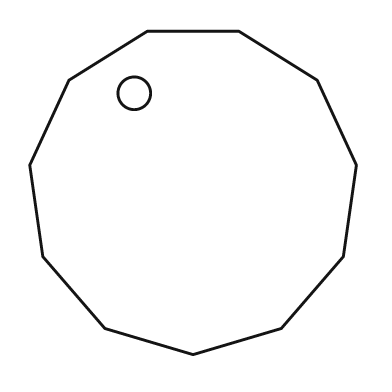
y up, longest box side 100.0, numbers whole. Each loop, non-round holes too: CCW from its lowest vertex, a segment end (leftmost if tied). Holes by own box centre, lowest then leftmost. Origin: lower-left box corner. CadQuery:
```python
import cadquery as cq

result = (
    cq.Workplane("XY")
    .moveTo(50.0, 0.0)
    .lineTo(77.0, 8.0)
    .lineTo(96.0, 30.0)
    .lineTo(100.0, 58.0)
    .lineTo(88.0, 84.0)
    .lineTo(64.0, 99.0)
    .lineTo(36.0, 99.0)
    .lineTo(12.0, 84.0)
    .lineTo(0.0, 58.0)
    .lineTo(4.0, 30.0)
    .lineTo(23.0, 8.0)
    .close()
    .moveTo(32.0, 80.0)
    .circle(5.0)
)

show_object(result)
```